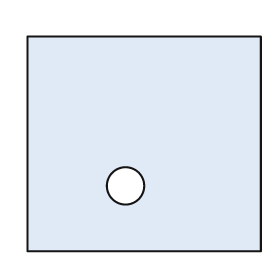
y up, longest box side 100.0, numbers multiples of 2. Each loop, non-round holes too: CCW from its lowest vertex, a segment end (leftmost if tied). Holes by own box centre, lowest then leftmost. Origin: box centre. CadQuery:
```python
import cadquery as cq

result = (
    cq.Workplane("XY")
    .moveTo(-50.0, -46.0)
    .lineTo(50.0, -46.0)
    .lineTo(50.0, 46.0)
    .lineTo(-50.0, 46.0)
    .close()
    .moveTo(-8.0, -18.0)
    .circle(8.0)
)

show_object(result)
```